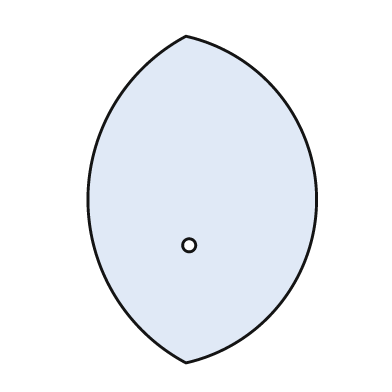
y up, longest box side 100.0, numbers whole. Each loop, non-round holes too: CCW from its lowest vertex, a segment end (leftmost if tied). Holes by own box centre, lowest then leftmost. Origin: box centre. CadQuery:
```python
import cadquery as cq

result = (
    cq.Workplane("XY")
    .moveTo(-5.0, -50.0)
    .threePointArc((35.0, 0.0), (-5.0, 50.0))
    .threePointArc((-35.0, 0.0), (-5.0, -50.0))
    .close()
    .moveTo(-4.0, -14.0)
    .circle(2.0)
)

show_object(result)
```